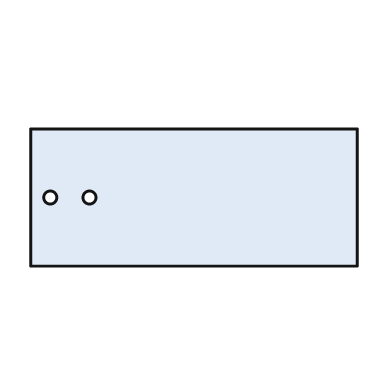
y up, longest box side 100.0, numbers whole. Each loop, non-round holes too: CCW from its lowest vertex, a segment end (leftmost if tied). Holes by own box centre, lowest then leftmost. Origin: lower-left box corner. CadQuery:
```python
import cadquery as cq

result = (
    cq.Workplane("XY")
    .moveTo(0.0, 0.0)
    .lineTo(100.0, 0.0)
    .lineTo(100.0, 42.0)
    .lineTo(0.0, 42.0)
    .close()
    .moveTo(6.0, 21.0)
    .circle(2.0)
    .moveTo(18.0, 21.0)
    .circle(2.0)
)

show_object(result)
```